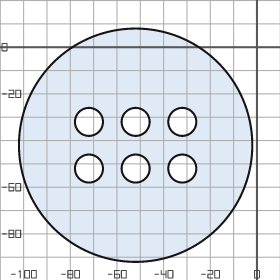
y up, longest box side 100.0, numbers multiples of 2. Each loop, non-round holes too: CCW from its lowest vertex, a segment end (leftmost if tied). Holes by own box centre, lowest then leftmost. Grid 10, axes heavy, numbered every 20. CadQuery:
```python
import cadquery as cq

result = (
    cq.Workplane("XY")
    .moveTo(-52.0, -42.0)
    .circle(50.0)
    .moveTo(-72.0, -52.0)
    .circle(6.0)
    .moveTo(-52.0, -52.0)
    .circle(6.0)
    .moveTo(-32.0, -52.0)
    .circle(6.0)
    .moveTo(-72.0, -32.0)
    .circle(6.0)
    .moveTo(-52.0, -32.0)
    .circle(6.0)
    .moveTo(-32.0, -32.0)
    .circle(6.0)
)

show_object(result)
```